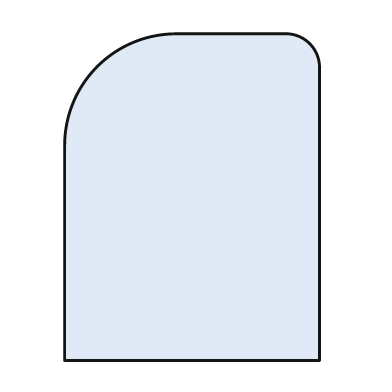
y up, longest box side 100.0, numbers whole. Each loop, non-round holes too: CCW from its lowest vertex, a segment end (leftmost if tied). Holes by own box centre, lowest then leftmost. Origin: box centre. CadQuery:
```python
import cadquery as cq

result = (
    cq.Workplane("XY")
    .moveTo(-39.0, -50.0)
    .lineTo(39.0, -50.0)
    .lineTo(39.0, 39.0)
    .threePointArc((36.0, 47.0), (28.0, 50.0))
    .lineTo(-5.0, 50.0)
    .threePointArc((-29.0, 40.0), (-39.0, 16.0))
    .close()
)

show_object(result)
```